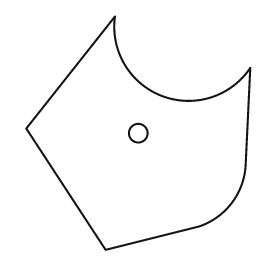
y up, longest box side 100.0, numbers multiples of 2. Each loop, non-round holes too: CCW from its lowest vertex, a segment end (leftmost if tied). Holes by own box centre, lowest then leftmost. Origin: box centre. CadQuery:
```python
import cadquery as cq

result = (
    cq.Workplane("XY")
    .moveTo(-14.0, -50.0)
    .lineTo(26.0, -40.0)
    .threePointArc((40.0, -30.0), (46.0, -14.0))
    .lineTo(48.0, 28.0)
    .threePointArc((10.0, 16.0), (-10.0, 50.0))
    .lineTo(-48.0, 2.0)
    .close()
    .moveTo(0.0, 0.0)
    .circle(4.0)
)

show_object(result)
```